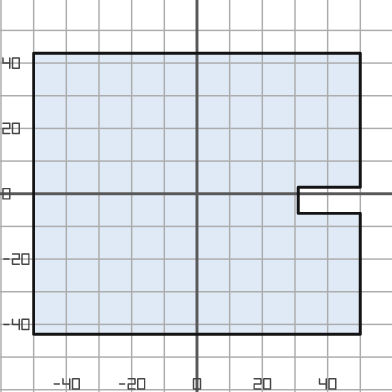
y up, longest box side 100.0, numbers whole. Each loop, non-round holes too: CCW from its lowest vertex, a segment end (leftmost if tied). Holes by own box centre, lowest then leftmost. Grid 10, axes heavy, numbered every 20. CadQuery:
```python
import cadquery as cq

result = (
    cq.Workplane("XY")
    .moveTo(-50.0, -43.0)
    .lineTo(50.0, -43.0)
    .lineTo(50.0, -6.0)
    .lineTo(31.0, -6.0)
    .lineTo(31.0, 2.0)
    .lineTo(50.0, 2.0)
    .lineTo(50.0, 43.0)
    .lineTo(-50.0, 43.0)
    .close()
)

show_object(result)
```